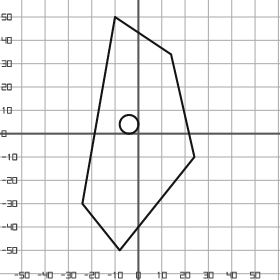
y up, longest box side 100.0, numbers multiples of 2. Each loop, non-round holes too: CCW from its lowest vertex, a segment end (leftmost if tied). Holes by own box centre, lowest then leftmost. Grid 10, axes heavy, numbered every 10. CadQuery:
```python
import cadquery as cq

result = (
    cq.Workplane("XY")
    .moveTo(-8.0, -50.0)
    .lineTo(24.0, -10.0)
    .lineTo(14.0, 34.0)
    .lineTo(-10.0, 50.0)
    .lineTo(-24.0, -30.0)
    .close()
    .moveTo(-4.0, 4.0)
    .circle(4.0)
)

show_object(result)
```